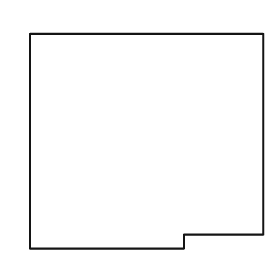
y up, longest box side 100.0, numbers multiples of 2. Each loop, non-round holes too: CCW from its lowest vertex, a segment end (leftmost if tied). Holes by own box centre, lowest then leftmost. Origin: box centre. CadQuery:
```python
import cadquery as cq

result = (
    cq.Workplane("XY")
    .moveTo(-50.0, -46.0)
    .lineTo(16.0, -46.0)
    .lineTo(16.0, -40.0)
    .lineTo(50.0, -40.0)
    .lineTo(50.0, 46.0)
    .lineTo(-50.0, 46.0)
    .close()
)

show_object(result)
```